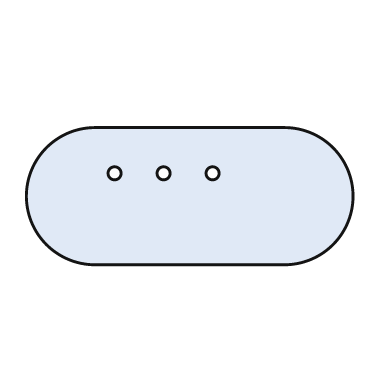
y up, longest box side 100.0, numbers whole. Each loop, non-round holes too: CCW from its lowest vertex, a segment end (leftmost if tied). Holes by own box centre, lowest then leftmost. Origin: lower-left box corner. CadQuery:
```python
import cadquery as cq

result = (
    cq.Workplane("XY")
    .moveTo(21.0, 0.0)
    .lineTo(79.0, 0.0)
    .threePointArc((100.0, 21.0), (79.0, 42.0))
    .lineTo(21.0, 42.0)
    .threePointArc((0.0, 21.0), (21.0, 0.0))
    .close()
    .moveTo(27.0, 28.0)
    .circle(2.0)
    .moveTo(42.0, 28.0)
    .circle(2.0)
    .moveTo(57.0, 28.0)
    .circle(2.0)
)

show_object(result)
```